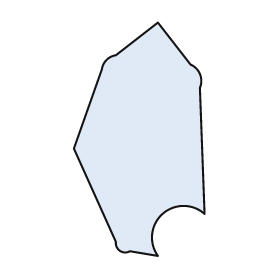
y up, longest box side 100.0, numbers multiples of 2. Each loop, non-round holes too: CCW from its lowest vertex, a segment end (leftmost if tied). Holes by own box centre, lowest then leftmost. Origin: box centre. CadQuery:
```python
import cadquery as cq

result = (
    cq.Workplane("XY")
    .moveTo(8.0, -50.0)
    .threePointArc((10.0, -32.0), (28.0, -32.0))
    .lineTo(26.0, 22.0)
    .threePointArc((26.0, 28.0), (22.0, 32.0))
    .lineTo(8.0, 50.0)
    .lineTo(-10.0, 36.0)
    .threePointArc((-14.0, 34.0), (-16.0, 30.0))
    .lineTo(-28.0, -4.0)
    .lineTo(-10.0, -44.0)
    .threePointArc((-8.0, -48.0), (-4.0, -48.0))
    .close()
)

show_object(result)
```